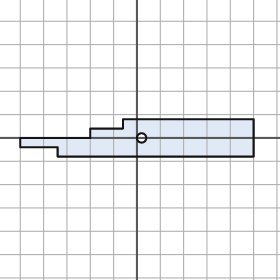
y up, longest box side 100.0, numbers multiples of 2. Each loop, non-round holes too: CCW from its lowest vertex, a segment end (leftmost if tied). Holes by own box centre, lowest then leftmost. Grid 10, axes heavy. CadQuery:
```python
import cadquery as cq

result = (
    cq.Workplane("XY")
    .moveTo(-34.0, -8.0)
    .lineTo(50.0, -8.0)
    .lineTo(50.0, 8.0)
    .lineTo(-6.0, 8.0)
    .lineTo(-6.0, 4.0)
    .lineTo(-20.0, 4.0)
    .lineTo(-20.0, 0.0)
    .lineTo(-50.0, 0.0)
    .lineTo(-50.0, -4.0)
    .lineTo(-34.0, -4.0)
    .close()
    .moveTo(2.0, 0.0)
    .circle(2.0)
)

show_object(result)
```